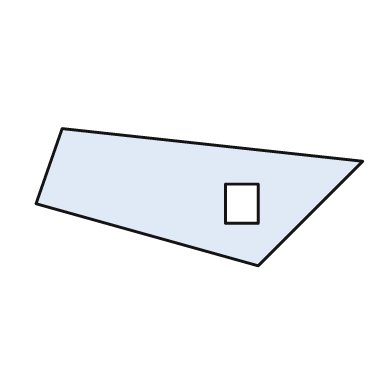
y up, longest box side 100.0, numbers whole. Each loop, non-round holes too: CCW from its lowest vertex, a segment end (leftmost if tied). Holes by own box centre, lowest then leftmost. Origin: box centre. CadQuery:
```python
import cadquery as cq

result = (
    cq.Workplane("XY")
    .moveTo(18.0, -21.0)
    .lineTo(50.0, 11.0)
    .lineTo(-42.0, 21.0)
    .lineTo(-50.0, -2.0)
    .close()
    .moveTo(8.0, -8.0)
    .lineTo(18.0, -8.0)
    .lineTo(18.0, 4.0)
    .lineTo(8.0, 4.0)
    .close()
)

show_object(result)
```